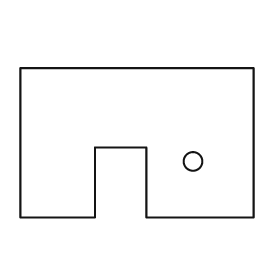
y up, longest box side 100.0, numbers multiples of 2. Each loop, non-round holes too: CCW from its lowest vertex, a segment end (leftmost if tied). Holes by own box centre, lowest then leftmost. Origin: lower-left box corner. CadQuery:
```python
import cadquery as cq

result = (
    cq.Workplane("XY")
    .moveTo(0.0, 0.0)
    .lineTo(32.0, 0.0)
    .lineTo(32.0, 30.0)
    .lineTo(54.0, 30.0)
    .lineTo(54.0, 0.0)
    .lineTo(100.0, 0.0)
    .lineTo(100.0, 64.0)
    .lineTo(0.0, 64.0)
    .close()
    .moveTo(74.0, 24.0)
    .circle(4.0)
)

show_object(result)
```